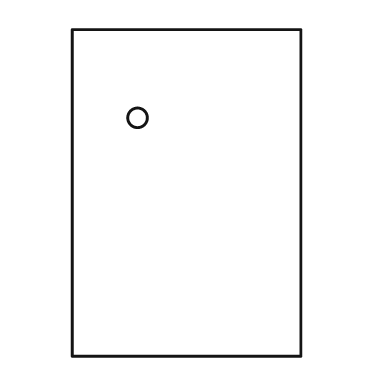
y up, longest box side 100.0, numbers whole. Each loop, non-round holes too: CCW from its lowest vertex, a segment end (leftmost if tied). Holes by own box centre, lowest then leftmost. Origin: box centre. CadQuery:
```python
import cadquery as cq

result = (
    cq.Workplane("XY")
    .moveTo(-35.0, -50.0)
    .lineTo(35.0, -50.0)
    .lineTo(35.0, 50.0)
    .lineTo(-35.0, 50.0)
    .close()
    .moveTo(-15.0, 23.0)
    .circle(3.0)
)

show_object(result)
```